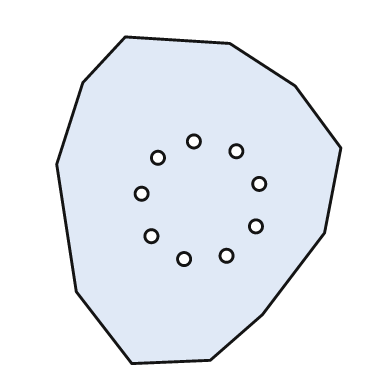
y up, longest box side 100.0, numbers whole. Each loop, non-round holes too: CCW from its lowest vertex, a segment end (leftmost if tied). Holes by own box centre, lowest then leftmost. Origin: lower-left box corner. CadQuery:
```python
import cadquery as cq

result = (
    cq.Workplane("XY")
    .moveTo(23.0, 0.0)
    .lineTo(47.0, 1.0)
    .lineTo(63.0, 15.0)
    .lineTo(82.0, 40.0)
    .lineTo(87.0, 66.0)
    .lineTo(73.0, 85.0)
    .lineTo(53.0, 98.0)
    .lineTo(21.0, 100.0)
    .lineTo(8.0, 86.0)
    .lineTo(0.0, 61.0)
    .lineTo(6.0, 22.0)
    .close()
    .moveTo(39.0, 32.0)
    .circle(2.0)
    .moveTo(52.0, 33.0)
    .circle(2.0)
    .moveTo(29.0, 39.0)
    .circle(2.0)
    .moveTo(61.0, 42.0)
    .circle(2.0)
    .moveTo(26.0, 52.0)
    .circle(2.0)
    .moveTo(62.0, 55.0)
    .circle(2.0)
    .moveTo(31.0, 63.0)
    .circle(2.0)
    .moveTo(55.0, 65.0)
    .circle(2.0)
    .moveTo(42.0, 68.0)
    .circle(2.0)
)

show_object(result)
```